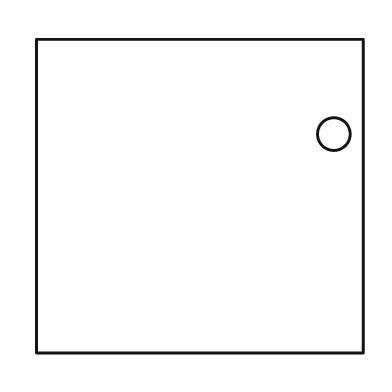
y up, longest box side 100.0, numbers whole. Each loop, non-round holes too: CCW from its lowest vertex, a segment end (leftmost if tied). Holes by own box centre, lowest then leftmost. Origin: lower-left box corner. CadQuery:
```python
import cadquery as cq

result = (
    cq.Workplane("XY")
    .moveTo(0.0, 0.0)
    .lineTo(100.0, 0.0)
    .lineTo(100.0, 96.0)
    .lineTo(0.0, 96.0)
    .close()
    .moveTo(91.0, 67.0)
    .circle(5.0)
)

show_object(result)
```